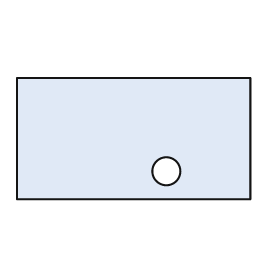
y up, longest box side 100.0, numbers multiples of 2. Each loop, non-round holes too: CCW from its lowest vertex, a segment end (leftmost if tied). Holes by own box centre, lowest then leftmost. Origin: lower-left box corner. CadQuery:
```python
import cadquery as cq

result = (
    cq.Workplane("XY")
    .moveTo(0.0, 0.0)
    .lineTo(100.0, 0.0)
    .lineTo(100.0, 52.0)
    .lineTo(0.0, 52.0)
    .close()
    .moveTo(64.0, 12.0)
    .circle(6.0)
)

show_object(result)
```